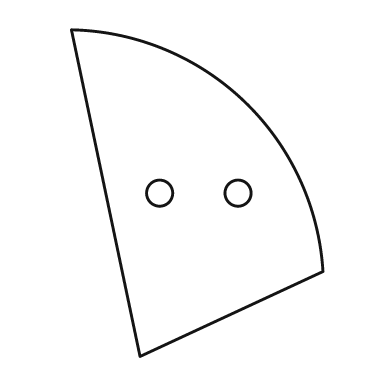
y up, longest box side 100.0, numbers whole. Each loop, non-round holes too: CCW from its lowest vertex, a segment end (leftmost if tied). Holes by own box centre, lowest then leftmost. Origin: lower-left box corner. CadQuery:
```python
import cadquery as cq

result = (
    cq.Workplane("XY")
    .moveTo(21.0, 0.0)
    .lineTo(77.0, 26.0)
    .threePointArc((53.0, 78.0), (0.0, 100.0))
    .close()
    .moveTo(27.0, 50.0)
    .circle(4.0)
    .moveTo(51.0, 50.0)
    .circle(4.0)
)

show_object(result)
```